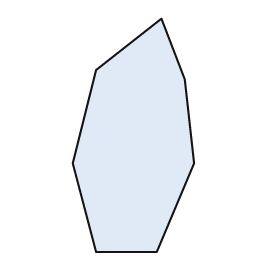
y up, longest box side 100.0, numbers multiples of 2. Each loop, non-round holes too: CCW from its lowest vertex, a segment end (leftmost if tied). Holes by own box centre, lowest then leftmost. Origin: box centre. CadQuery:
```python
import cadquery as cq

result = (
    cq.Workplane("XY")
    .moveTo(-16.0, -50.0)
    .lineTo(10.0, -50.0)
    .lineTo(26.0, -12.0)
    .lineTo(22.0, 24.0)
    .lineTo(12.0, 50.0)
    .lineTo(-16.0, 28.0)
    .lineTo(-26.0, -12.0)
    .close()
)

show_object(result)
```